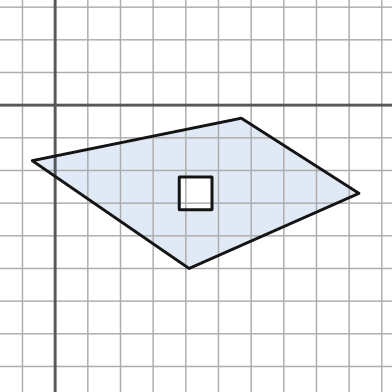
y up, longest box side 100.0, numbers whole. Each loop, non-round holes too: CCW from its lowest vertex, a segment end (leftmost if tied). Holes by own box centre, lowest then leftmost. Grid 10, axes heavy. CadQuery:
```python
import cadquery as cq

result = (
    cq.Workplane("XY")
    .moveTo(41.0, -50.0)
    .lineTo(93.0, -27.0)
    .lineTo(57.0, -4.0)
    .lineTo(-7.0, -17.0)
    .close()
    .moveTo(38.0, -32.0)
    .lineTo(48.0, -32.0)
    .lineTo(48.0, -22.0)
    .lineTo(38.0, -22.0)
    .close()
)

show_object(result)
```